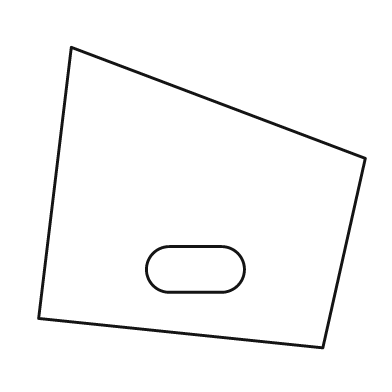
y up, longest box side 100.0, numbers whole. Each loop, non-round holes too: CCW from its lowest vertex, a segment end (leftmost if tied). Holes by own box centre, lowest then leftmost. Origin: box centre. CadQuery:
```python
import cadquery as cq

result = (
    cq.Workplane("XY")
    .moveTo(37.0, -46.0)
    .lineTo(50.0, 12.0)
    .lineTo(-40.0, 46.0)
    .lineTo(-50.0, -37.0)
    .close()
    .moveTo(-10.0, -29.0)
    .lineTo(6.0, -29.0)
    .threePointArc((13.0, -22.0), (6.0, -15.0))
    .lineTo(-10.0, -15.0)
    .threePointArc((-17.0, -22.0), (-10.0, -29.0))
    .close()
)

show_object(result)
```